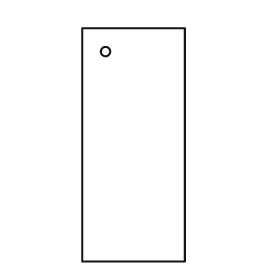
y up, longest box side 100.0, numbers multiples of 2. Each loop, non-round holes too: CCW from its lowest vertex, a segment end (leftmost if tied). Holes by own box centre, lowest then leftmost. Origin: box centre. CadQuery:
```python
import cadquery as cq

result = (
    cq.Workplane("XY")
    .moveTo(-22.0, -50.0)
    .lineTo(22.0, -50.0)
    .lineTo(22.0, 50.0)
    .lineTo(-22.0, 50.0)
    .close()
    .moveTo(-12.0, 40.0)
    .circle(2.0)
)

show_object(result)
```